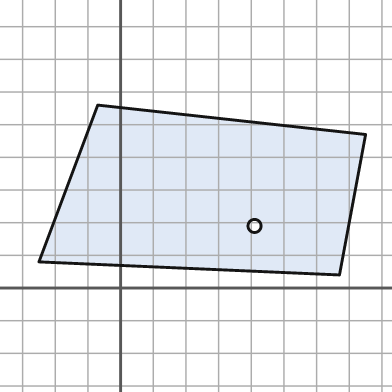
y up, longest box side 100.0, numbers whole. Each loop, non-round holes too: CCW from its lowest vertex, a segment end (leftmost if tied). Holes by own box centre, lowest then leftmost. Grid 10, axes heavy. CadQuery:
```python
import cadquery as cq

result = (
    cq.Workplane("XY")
    .moveTo(67.0, 4.0)
    .lineTo(75.0, 47.0)
    .lineTo(-7.0, 56.0)
    .lineTo(-25.0, 8.0)
    .close()
    .moveTo(41.0, 19.0)
    .circle(2.0)
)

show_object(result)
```